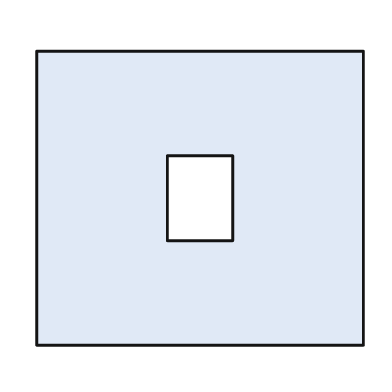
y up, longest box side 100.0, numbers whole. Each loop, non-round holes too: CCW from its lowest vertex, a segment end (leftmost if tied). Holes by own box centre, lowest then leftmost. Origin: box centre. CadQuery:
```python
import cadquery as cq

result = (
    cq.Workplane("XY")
    .moveTo(-50.0, -45.0)
    .lineTo(50.0, -45.0)
    .lineTo(50.0, 45.0)
    .lineTo(-50.0, 45.0)
    .close()
    .moveTo(-10.0, -13.0)
    .lineTo(10.0, -13.0)
    .lineTo(10.0, 13.0)
    .lineTo(-10.0, 13.0)
    .close()
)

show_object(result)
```